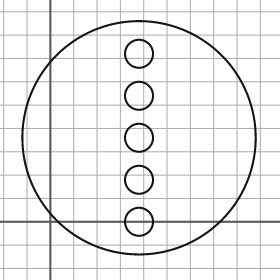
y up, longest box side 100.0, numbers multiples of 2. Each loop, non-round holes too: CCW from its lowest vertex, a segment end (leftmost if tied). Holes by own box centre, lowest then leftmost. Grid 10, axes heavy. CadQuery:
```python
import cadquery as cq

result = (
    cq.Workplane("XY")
    .moveTo(38.0, 36.0)
    .circle(50.0)
    .moveTo(38.0, 0.0)
    .circle(6.0)
    .moveTo(38.0, 18.0)
    .circle(6.0)
    .moveTo(38.0, 36.0)
    .circle(6.0)
    .moveTo(38.0, 54.0)
    .circle(6.0)
    .moveTo(38.0, 72.0)
    .circle(6.0)
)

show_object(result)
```